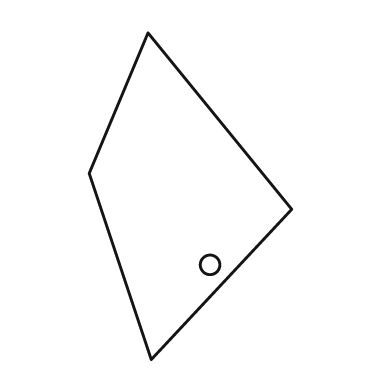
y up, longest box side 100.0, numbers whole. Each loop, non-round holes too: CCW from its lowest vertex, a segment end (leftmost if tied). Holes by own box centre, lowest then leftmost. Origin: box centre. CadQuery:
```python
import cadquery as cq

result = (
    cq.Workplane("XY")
    .moveTo(-12.0, -50.0)
    .lineTo(31.0, -4.0)
    .lineTo(-13.0, 50.0)
    .lineTo(-31.0, 7.0)
    .close()
    .moveTo(6.0, -21.0)
    .circle(3.0)
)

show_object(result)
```